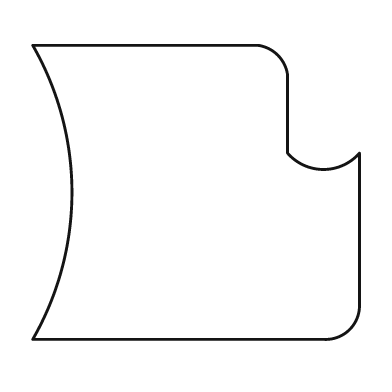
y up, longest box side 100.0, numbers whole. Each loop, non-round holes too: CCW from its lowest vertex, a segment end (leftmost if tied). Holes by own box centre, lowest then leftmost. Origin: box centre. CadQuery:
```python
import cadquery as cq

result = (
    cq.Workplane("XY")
    .moveTo(-50.0, -45.0)
    .lineTo(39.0, -45.0)
    .threePointArc((47.0, -42.0), (50.0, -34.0))
    .lineTo(50.0, 12.0)
    .threePointArc((39.0, 7.0), (28.0, 12.0))
    .lineTo(28.0, 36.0)
    .threePointArc((25.0, 42.0), (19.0, 45.0))
    .lineTo(-50.0, 45.0)
    .threePointArc((-38.0, 0.0), (-50.0, -45.0))
    .close()
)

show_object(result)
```